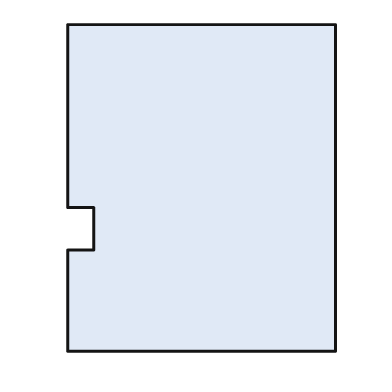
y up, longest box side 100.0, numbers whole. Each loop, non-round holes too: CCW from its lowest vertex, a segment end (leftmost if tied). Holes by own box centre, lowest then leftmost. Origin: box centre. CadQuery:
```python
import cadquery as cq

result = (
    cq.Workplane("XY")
    .moveTo(-41.0, -50.0)
    .lineTo(41.0, -50.0)
    .lineTo(41.0, 50.0)
    .lineTo(-41.0, 50.0)
    .lineTo(-41.0, -6.0)
    .lineTo(-33.0, -6.0)
    .lineTo(-33.0, -19.0)
    .lineTo(-41.0, -19.0)
    .close()
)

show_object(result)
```